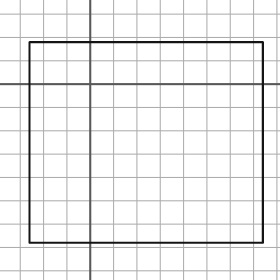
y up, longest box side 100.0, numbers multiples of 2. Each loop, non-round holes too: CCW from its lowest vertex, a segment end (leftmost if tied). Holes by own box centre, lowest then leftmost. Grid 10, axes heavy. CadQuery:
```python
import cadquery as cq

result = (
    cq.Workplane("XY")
    .moveTo(-26.0, -68.0)
    .lineTo(74.0, -68.0)
    .lineTo(74.0, 18.0)
    .lineTo(-26.0, 18.0)
    .close()
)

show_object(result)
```